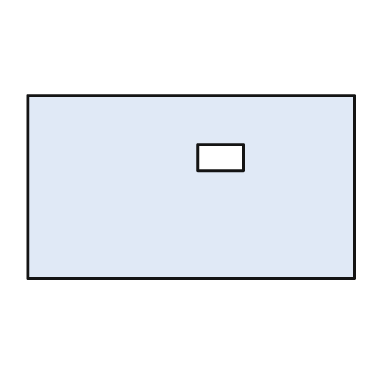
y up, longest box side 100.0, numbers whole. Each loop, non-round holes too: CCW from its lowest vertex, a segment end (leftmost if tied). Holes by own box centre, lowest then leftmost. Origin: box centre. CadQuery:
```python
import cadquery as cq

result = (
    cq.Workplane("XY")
    .moveTo(-50.0, -28.0)
    .lineTo(50.0, -28.0)
    .lineTo(50.0, 28.0)
    .lineTo(-50.0, 28.0)
    .close()
    .moveTo(2.0, 5.0)
    .lineTo(16.0, 5.0)
    .lineTo(16.0, 13.0)
    .lineTo(2.0, 13.0)
    .close()
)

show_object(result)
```